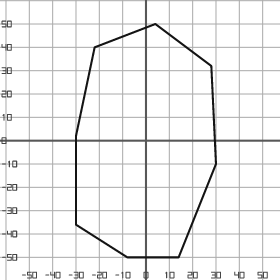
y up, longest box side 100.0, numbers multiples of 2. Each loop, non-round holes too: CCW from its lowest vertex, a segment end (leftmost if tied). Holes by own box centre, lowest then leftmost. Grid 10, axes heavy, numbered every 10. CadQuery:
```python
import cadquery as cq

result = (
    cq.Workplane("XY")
    .moveTo(-8.0, -50.0)
    .lineTo(14.0, -50.0)
    .lineTo(30.0, -10.0)
    .lineTo(28.0, 32.0)
    .lineTo(4.0, 50.0)
    .lineTo(-22.0, 40.0)
    .lineTo(-30.0, 2.0)
    .lineTo(-30.0, -36.0)
    .close()
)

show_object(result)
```